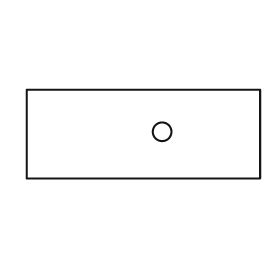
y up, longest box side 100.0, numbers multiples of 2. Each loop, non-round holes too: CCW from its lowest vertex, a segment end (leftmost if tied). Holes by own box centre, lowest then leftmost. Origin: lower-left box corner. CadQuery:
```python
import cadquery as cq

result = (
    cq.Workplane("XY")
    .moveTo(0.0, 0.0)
    .lineTo(100.0, 0.0)
    .lineTo(100.0, 38.0)
    .lineTo(0.0, 38.0)
    .close()
    .moveTo(58.0, 20.0)
    .circle(4.0)
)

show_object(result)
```